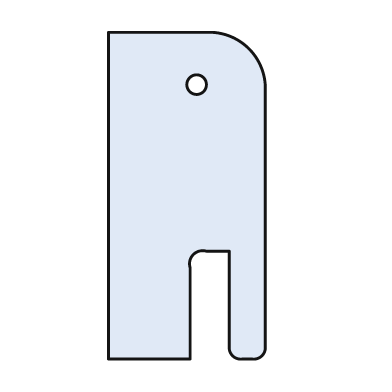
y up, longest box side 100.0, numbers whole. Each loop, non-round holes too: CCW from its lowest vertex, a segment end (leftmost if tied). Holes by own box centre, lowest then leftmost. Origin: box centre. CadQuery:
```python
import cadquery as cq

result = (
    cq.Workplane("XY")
    .moveTo(-24.0, -50.0)
    .lineTo(1.0, -50.0)
    .lineTo(1.0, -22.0)
    .threePointArc((2.0, -18.0), (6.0, -17.0))
    .lineTo(13.0, -17.0)
    .lineTo(13.0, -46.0)
    .threePointArc((14.0, -49.0), (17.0, -50.0))
    .lineTo(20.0, -50.0)
    .threePointArc((23.0, -49.0), (24.0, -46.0))
    .lineTo(24.0, 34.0)
    .threePointArc((19.0, 45.0), (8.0, 50.0))
    .lineTo(-24.0, 50.0)
    .close()
    .moveTo(3.0, 34.0)
    .circle(3.0)
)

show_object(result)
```